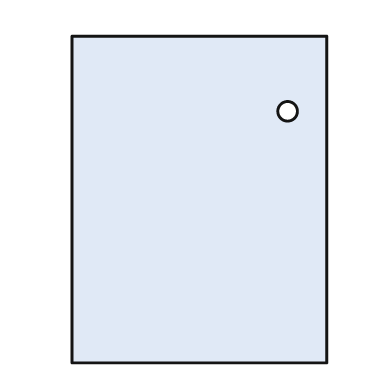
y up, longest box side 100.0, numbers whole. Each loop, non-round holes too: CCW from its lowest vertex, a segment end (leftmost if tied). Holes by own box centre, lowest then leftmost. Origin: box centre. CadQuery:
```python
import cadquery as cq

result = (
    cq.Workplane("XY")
    .moveTo(-39.0, -50.0)
    .lineTo(39.0, -50.0)
    .lineTo(39.0, 50.0)
    .lineTo(-39.0, 50.0)
    .close()
    .moveTo(27.0, 27.0)
    .circle(3.0)
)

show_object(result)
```